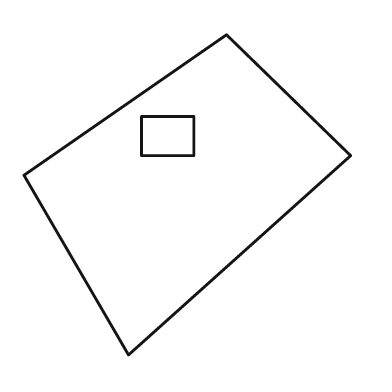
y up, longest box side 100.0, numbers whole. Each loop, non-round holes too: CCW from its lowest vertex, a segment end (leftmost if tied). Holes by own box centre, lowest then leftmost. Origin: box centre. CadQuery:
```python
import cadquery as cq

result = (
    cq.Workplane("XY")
    .moveTo(-18.0, -49.0)
    .lineTo(50.0, 12.0)
    .lineTo(12.0, 49.0)
    .lineTo(-50.0, 6.0)
    .close()
    .moveTo(-14.0, 12.0)
    .lineTo(2.0, 12.0)
    .lineTo(2.0, 24.0)
    .lineTo(-14.0, 24.0)
    .close()
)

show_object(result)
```